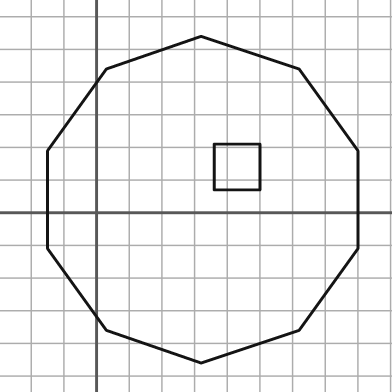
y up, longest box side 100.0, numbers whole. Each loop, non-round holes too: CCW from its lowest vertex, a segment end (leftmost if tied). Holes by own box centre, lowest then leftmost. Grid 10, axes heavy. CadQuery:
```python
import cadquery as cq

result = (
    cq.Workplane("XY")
    .moveTo(32.0, -46.0)
    .lineTo(62.0, -36.0)
    .lineTo(80.0, -11.0)
    .lineTo(80.0, 19.0)
    .lineTo(62.0, 44.0)
    .lineTo(32.0, 54.0)
    .lineTo(3.0, 44.0)
    .lineTo(-15.0, 19.0)
    .lineTo(-15.0, -11.0)
    .lineTo(3.0, -36.0)
    .close()
    .moveTo(36.0, 7.0)
    .lineTo(50.0, 7.0)
    .lineTo(50.0, 21.0)
    .lineTo(36.0, 21.0)
    .close()
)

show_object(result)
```